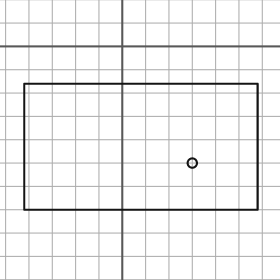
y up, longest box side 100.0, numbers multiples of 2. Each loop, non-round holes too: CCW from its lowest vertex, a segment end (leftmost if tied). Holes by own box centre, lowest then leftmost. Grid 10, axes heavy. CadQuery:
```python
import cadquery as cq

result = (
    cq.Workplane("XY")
    .moveTo(-42.0, -70.0)
    .lineTo(58.0, -70.0)
    .lineTo(58.0, -16.0)
    .lineTo(-42.0, -16.0)
    .close()
    .moveTo(30.0, -50.0)
    .circle(2.0)
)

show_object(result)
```